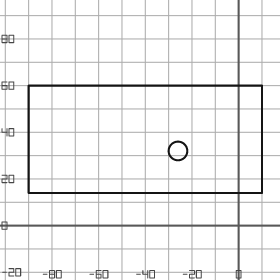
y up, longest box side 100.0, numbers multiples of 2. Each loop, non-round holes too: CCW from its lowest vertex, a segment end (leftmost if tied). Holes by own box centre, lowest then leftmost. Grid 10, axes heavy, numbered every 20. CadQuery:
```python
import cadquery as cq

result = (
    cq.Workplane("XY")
    .moveTo(-90.0, 14.0)
    .lineTo(10.0, 14.0)
    .lineTo(10.0, 60.0)
    .lineTo(-90.0, 60.0)
    .close()
    .moveTo(-26.0, 32.0)
    .circle(4.0)
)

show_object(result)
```